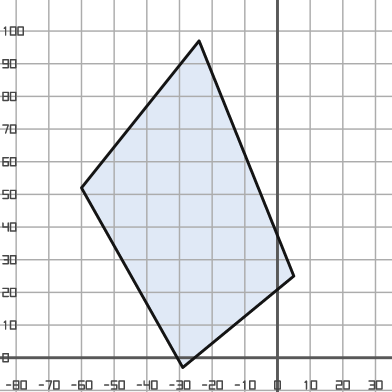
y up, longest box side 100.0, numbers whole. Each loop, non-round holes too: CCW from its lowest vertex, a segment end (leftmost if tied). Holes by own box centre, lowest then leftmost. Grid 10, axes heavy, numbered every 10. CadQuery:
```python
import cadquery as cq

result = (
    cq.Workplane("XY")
    .moveTo(-29.0, -3.0)
    .lineTo(5.0, 25.0)
    .lineTo(-24.0, 97.0)
    .lineTo(-60.0, 52.0)
    .close()
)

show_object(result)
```